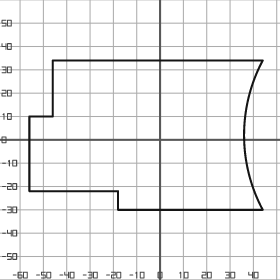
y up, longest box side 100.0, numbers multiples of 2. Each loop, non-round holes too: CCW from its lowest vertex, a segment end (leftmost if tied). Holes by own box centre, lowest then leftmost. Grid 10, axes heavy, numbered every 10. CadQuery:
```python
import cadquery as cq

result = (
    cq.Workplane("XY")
    .moveTo(-18.0, -30.0)
    .lineTo(44.0, -30.0)
    .threePointArc((36.0, 2.0), (44.0, 34.0))
    .lineTo(-46.0, 34.0)
    .lineTo(-46.0, 10.0)
    .lineTo(-56.0, 10.0)
    .lineTo(-56.0, -22.0)
    .lineTo(-18.0, -22.0)
    .close()
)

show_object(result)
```